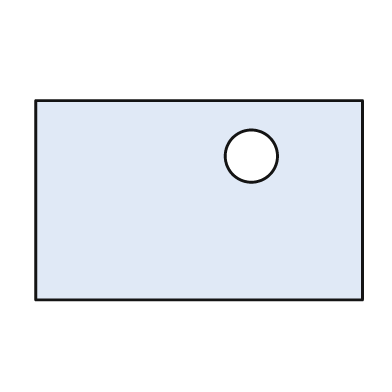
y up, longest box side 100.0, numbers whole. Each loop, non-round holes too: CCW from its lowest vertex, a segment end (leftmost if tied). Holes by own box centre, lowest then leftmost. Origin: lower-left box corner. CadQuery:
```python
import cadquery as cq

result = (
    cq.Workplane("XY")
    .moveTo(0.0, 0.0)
    .lineTo(100.0, 0.0)
    .lineTo(100.0, 61.0)
    .lineTo(0.0, 61.0)
    .close()
    .moveTo(66.0, 44.0)
    .circle(8.0)
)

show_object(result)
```